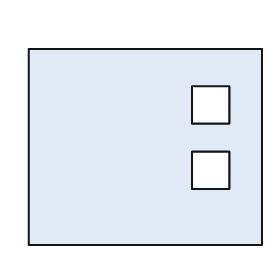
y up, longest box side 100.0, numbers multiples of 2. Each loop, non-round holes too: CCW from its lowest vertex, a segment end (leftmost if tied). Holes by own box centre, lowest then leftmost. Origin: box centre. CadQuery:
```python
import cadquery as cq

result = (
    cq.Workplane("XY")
    .moveTo(-50.0, -42.0)
    .lineTo(50.0, -42.0)
    .lineTo(50.0, 42.0)
    .lineTo(-50.0, 42.0)
    .close()
    .moveTo(20.0, -18.0)
    .lineTo(36.0, -18.0)
    .lineTo(36.0, -2.0)
    .lineTo(20.0, -2.0)
    .close()
    .moveTo(20.0, 10.0)
    .lineTo(36.0, 10.0)
    .lineTo(36.0, 26.0)
    .lineTo(20.0, 26.0)
    .close()
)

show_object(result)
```